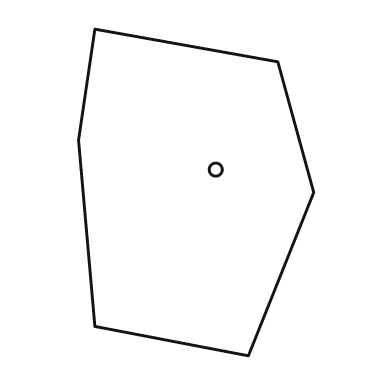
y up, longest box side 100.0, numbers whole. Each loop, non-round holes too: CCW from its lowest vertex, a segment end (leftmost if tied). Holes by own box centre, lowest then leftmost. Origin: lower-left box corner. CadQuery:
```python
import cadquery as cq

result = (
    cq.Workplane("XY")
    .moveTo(52.0, 0.0)
    .lineTo(72.0, 50.0)
    .lineTo(61.0, 90.0)
    .lineTo(5.0, 100.0)
    .lineTo(0.0, 66.0)
    .lineTo(5.0, 9.0)
    .close()
    .moveTo(42.0, 57.0)
    .circle(2.0)
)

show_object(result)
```